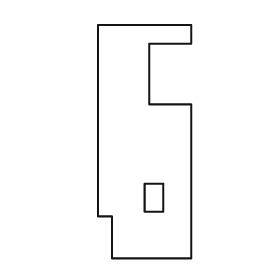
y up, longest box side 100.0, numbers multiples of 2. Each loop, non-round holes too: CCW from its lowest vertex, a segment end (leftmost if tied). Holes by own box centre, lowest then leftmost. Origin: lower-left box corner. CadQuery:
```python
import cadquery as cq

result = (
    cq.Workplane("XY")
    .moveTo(6.0, 0.0)
    .lineTo(40.0, 0.0)
    .lineTo(40.0, 66.0)
    .lineTo(22.0, 66.0)
    .lineTo(22.0, 92.0)
    .lineTo(40.0, 92.0)
    .lineTo(40.0, 100.0)
    .lineTo(0.0, 100.0)
    .lineTo(0.0, 18.0)
    .lineTo(6.0, 18.0)
    .close()
    .moveTo(20.0, 20.0)
    .lineTo(28.0, 20.0)
    .lineTo(28.0, 32.0)
    .lineTo(20.0, 32.0)
    .close()
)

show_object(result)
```